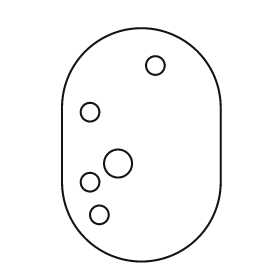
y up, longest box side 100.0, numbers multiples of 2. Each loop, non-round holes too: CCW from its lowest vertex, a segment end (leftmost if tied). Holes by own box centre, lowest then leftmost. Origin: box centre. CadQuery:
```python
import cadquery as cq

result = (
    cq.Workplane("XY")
    .moveTo(-34.0, -16.0)
    .threePointArc((0.0, -50.0), (34.0, -16.0))
    .lineTo(34.0, 16.0)
    .threePointArc((0.0, 50.0), (-34.0, 16.0))
    .close()
    .moveTo(-18.0, -30.0)
    .circle(4.0)
    .moveTo(-22.0, -16.0)
    .circle(4.0)
    .moveTo(-10.0, -8.0)
    .circle(6.0)
    .moveTo(-22.0, 14.0)
    .circle(4.0)
    .moveTo(6.0, 34.0)
    .circle(4.0)
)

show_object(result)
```